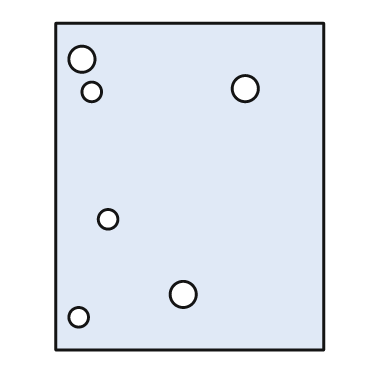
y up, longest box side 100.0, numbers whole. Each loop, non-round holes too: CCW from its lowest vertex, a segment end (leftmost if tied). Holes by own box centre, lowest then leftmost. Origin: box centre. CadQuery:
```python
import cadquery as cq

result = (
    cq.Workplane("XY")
    .moveTo(-41.0, -50.0)
    .lineTo(41.0, -50.0)
    .lineTo(41.0, 50.0)
    .lineTo(-41.0, 50.0)
    .close()
    .moveTo(-34.0, -40.0)
    .circle(3.0)
    .moveTo(-2.0, -33.0)
    .circle(4.0)
    .moveTo(-25.0, -10.0)
    .circle(3.0)
    .moveTo(-30.0, 29.0)
    .circle(3.0)
    .moveTo(17.0, 30.0)
    .circle(4.0)
    .moveTo(-33.0, 39.0)
    .circle(4.0)
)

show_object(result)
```